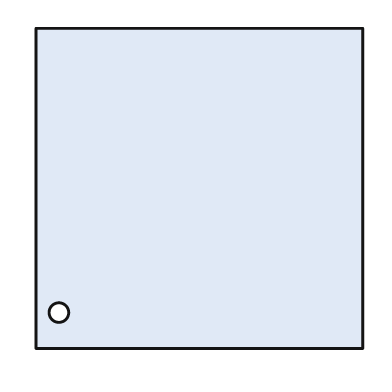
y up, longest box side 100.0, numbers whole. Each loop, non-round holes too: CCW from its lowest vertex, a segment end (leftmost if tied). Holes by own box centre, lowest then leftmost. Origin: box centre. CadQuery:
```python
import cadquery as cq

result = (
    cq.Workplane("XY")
    .moveTo(-50.0, -49.0)
    .lineTo(50.0, -49.0)
    .lineTo(50.0, 49.0)
    .lineTo(-50.0, 49.0)
    .close()
    .moveTo(-43.0, -38.0)
    .circle(3.0)
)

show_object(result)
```